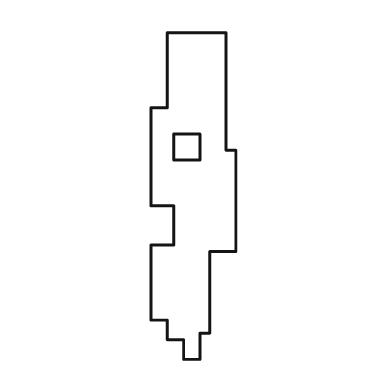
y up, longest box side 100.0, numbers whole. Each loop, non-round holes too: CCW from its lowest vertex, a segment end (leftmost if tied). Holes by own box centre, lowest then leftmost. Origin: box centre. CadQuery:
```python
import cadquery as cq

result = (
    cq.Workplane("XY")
    .moveTo(-3.0, -50.0)
    .lineTo(2.0, -50.0)
    .lineTo(2.0, -42.0)
    .lineTo(5.0, -42.0)
    .lineTo(5.0, -17.0)
    .lineTo(13.0, -17.0)
    .lineTo(13.0, 14.0)
    .lineTo(10.0, 14.0)
    .lineTo(10.0, 50.0)
    .lineTo(-8.0, 50.0)
    .lineTo(-8.0, 27.0)
    .lineTo(-13.0, 27.0)
    .lineTo(-13.0, -3.0)
    .lineTo(-6.0, -3.0)
    .lineTo(-6.0, -15.0)
    .lineTo(-13.0, -15.0)
    .lineTo(-13.0, -38.0)
    .lineTo(-8.0, -38.0)
    .lineTo(-8.0, -44.0)
    .lineTo(-3.0, -44.0)
    .close()
    .moveTo(-6.0, 11.0)
    .lineTo(2.0, 11.0)
    .lineTo(2.0, 19.0)
    .lineTo(-6.0, 19.0)
    .close()
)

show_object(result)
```